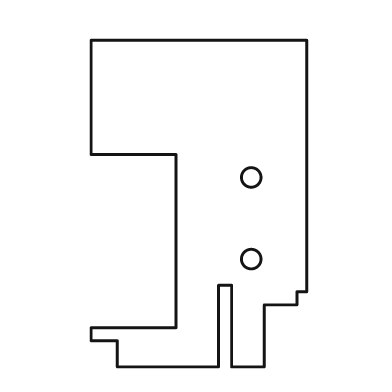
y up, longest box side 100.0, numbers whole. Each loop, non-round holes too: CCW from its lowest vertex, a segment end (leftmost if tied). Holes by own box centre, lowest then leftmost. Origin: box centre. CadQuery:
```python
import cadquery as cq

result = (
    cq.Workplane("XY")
    .moveTo(-25.0, -50.0)
    .lineTo(6.0, -50.0)
    .lineTo(6.0, -25.0)
    .lineTo(10.0, -25.0)
    .lineTo(10.0, -50.0)
    .lineTo(20.0, -50.0)
    .lineTo(20.0, -31.0)
    .lineTo(30.0, -31.0)
    .lineTo(30.0, -27.0)
    .lineTo(33.0, -27.0)
    .lineTo(33.0, 50.0)
    .lineTo(-33.0, 50.0)
    .lineTo(-33.0, 15.0)
    .lineTo(-7.0, 15.0)
    .lineTo(-7.0, -38.0)
    .lineTo(-33.0, -38.0)
    .lineTo(-33.0, -42.0)
    .lineTo(-25.0, -42.0)
    .close()
    .moveTo(16.0, -17.0)
    .circle(3.0)
    .moveTo(16.0, 8.0)
    .circle(3.0)
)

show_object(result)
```